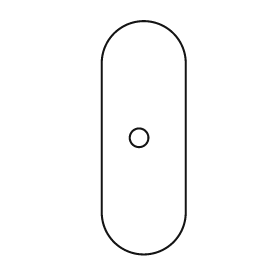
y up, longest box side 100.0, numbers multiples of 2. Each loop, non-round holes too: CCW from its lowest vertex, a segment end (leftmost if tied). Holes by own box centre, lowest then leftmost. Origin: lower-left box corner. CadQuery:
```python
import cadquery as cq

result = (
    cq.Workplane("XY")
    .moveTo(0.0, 18.0)
    .threePointArc((18.0, 0.0), (36.0, 18.0))
    .lineTo(36.0, 82.0)
    .threePointArc((18.0, 100.0), (0.0, 82.0))
    .close()
    .moveTo(16.0, 50.0)
    .circle(4.0)
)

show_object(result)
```